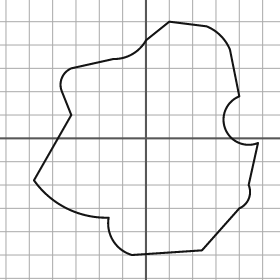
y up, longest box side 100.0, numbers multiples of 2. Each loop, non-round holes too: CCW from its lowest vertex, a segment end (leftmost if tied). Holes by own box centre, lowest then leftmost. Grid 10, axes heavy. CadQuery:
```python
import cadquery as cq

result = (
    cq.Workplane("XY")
    .moveTo(-6.0, -50.0)
    .lineTo(24.0, -48.0)
    .lineTo(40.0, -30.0)
    .threePointArc((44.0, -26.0), (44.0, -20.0))
    .lineTo(48.0, -2.0)
    .threePointArc((34.0, 4.0), (40.0, 18.0))
    .lineTo(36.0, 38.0)
    .threePointArc((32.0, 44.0), (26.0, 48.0))
    .lineTo(10.0, 50.0)
    .lineTo(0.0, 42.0)
    .threePointArc((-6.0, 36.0), (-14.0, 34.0))
    .lineTo(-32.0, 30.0)
    .threePointArc((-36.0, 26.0), (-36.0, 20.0))
    .lineTo(-32.0, 10.0)
    .lineTo(-48.0, -18.0)
    .threePointArc((-34.0, -30.0), (-16.0, -34.0))
    .threePointArc((-14.0, -44.0), (-6.0, -50.0))
    .close()
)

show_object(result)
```